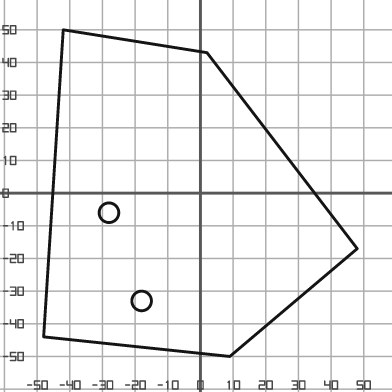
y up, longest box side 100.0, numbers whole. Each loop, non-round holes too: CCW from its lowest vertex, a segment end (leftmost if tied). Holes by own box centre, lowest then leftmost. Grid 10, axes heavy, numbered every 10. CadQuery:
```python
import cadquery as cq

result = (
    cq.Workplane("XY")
    .moveTo(9.0, -50.0)
    .lineTo(48.0, -17.0)
    .lineTo(2.0, 43.0)
    .lineTo(-42.0, 50.0)
    .lineTo(-48.0, -44.0)
    .close()
    .moveTo(-18.0, -33.0)
    .circle(3.0)
    .moveTo(-28.0, -6.0)
    .circle(3.0)
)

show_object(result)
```